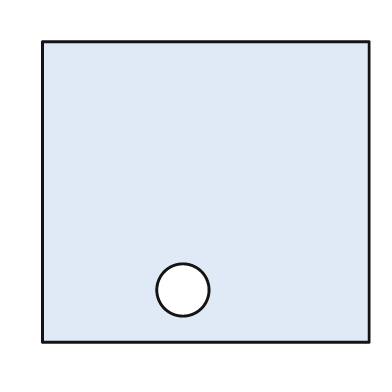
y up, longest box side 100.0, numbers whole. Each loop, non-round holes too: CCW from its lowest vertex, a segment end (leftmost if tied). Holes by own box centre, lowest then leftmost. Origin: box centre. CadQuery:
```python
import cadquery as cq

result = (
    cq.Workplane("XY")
    .moveTo(-50.0, -46.0)
    .lineTo(50.0, -46.0)
    .lineTo(50.0, 46.0)
    .lineTo(-50.0, 46.0)
    .close()
    .moveTo(-7.0, -30.0)
    .circle(8.0)
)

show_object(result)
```